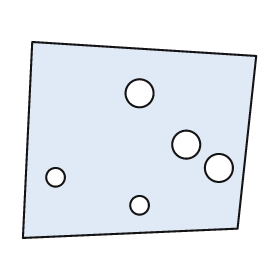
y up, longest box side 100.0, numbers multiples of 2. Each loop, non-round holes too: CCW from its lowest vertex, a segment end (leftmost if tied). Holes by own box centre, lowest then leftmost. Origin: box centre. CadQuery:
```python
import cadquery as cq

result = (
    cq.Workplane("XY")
    .moveTo(-50.0, -42.0)
    .lineTo(42.0, -38.0)
    .lineTo(50.0, 36.0)
    .lineTo(-46.0, 42.0)
    .close()
    .moveTo(0.0, -28.0)
    .circle(4.0)
    .moveTo(-36.0, -16.0)
    .circle(4.0)
    .moveTo(34.0, -12.0)
    .circle(6.0)
    .moveTo(20.0, -2.0)
    .circle(6.0)
    .moveTo(0.0, 20.0)
    .circle(6.0)
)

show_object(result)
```